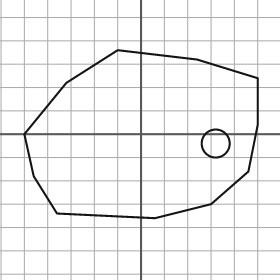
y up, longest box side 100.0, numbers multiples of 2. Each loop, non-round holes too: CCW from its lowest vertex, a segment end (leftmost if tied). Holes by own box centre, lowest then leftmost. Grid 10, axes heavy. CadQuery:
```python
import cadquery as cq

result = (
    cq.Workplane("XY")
    .moveTo(6.0, -36.0)
    .lineTo(30.0, -30.0)
    .lineTo(46.0, -16.0)
    .lineTo(50.0, 4.0)
    .lineTo(50.0, 24.0)
    .lineTo(24.0, 32.0)
    .lineTo(-10.0, 36.0)
    .lineTo(-32.0, 22.0)
    .lineTo(-50.0, 0.0)
    .lineTo(-46.0, -18.0)
    .lineTo(-36.0, -34.0)
    .close()
    .moveTo(32.0, -4.0)
    .circle(6.0)
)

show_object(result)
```